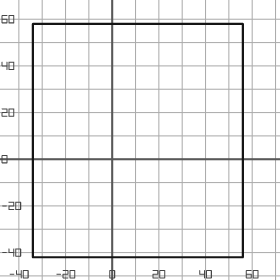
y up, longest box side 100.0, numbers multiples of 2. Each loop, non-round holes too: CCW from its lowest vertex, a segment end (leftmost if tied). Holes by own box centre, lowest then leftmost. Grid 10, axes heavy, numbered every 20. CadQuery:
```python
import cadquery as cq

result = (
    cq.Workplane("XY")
    .moveTo(-34.0, -42.0)
    .lineTo(56.0, -42.0)
    .lineTo(56.0, 58.0)
    .lineTo(-34.0, 58.0)
    .close()
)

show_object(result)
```